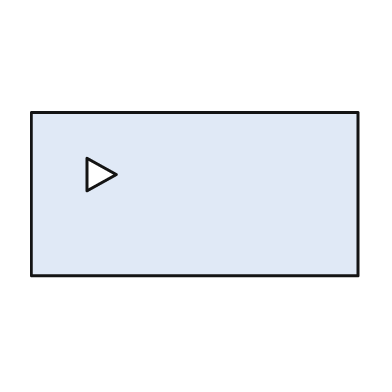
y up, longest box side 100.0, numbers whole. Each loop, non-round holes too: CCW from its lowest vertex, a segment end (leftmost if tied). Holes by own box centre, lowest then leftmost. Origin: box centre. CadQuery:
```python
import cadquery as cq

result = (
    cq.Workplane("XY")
    .moveTo(-50.0, -25.0)
    .lineTo(50.0, -25.0)
    .lineTo(50.0, 25.0)
    .lineTo(-50.0, 25.0)
    .close()
    .moveTo(-33.0, 1.0)
    .lineTo(-24.0, 6.0)
    .lineTo(-33.0, 11.0)
    .close()
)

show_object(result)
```